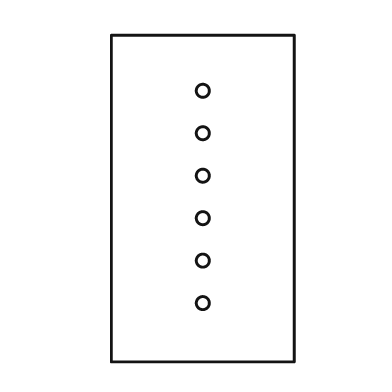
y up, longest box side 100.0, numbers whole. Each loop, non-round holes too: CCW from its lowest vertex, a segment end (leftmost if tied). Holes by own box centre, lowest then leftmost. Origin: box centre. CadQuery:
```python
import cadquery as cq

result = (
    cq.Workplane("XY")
    .moveTo(-28.0, -50.0)
    .lineTo(28.0, -50.0)
    .lineTo(28.0, 50.0)
    .lineTo(-28.0, 50.0)
    .close()
    .moveTo(0.0, -32.0)
    .circle(2.0)
    .moveTo(0.0, -19.0)
    .circle(2.0)
    .moveTo(0.0, -6.0)
    .circle(2.0)
    .moveTo(0.0, 7.0)
    .circle(2.0)
    .moveTo(0.0, 20.0)
    .circle(2.0)
    .moveTo(0.0, 33.0)
    .circle(2.0)
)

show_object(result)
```